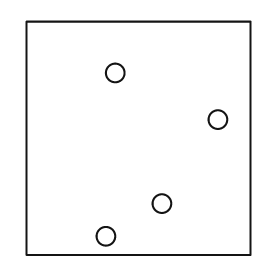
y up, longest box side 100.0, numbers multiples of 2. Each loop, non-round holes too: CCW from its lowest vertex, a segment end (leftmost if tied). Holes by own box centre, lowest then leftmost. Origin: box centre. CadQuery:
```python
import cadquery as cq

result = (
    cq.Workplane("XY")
    .moveTo(-48.0, -50.0)
    .lineTo(48.0, -50.0)
    .lineTo(48.0, 50.0)
    .lineTo(-48.0, 50.0)
    .close()
    .moveTo(-14.0, -42.0)
    .circle(4.0)
    .moveTo(10.0, -28.0)
    .circle(4.0)
    .moveTo(34.0, 8.0)
    .circle(4.0)
    .moveTo(-10.0, 28.0)
    .circle(4.0)
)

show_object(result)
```